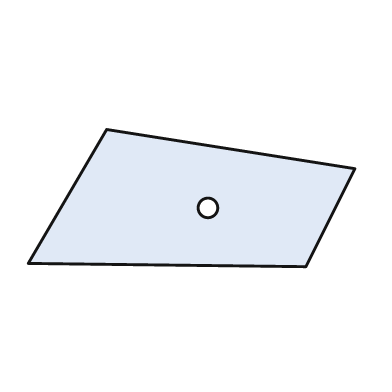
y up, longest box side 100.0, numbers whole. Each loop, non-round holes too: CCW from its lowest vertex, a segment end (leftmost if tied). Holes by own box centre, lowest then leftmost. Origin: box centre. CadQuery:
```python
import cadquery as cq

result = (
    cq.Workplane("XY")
    .moveTo(35.0, -21.0)
    .lineTo(50.0, 9.0)
    .lineTo(-26.0, 21.0)
    .lineTo(-50.0, -20.0)
    .close()
    .moveTo(5.0, -3.0)
    .circle(3.0)
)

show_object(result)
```